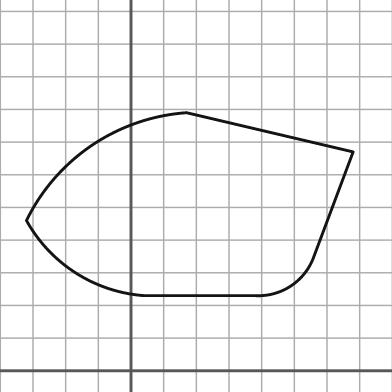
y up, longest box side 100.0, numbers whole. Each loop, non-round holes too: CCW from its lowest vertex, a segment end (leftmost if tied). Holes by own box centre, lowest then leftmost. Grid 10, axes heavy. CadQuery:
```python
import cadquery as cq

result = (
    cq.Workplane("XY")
    .moveTo(4.0, 23.0)
    .lineTo(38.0, 23.0)
    .threePointArc((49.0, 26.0), (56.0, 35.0))
    .lineTo(68.0, 67.0)
    .lineTo(17.0, 79.0)
    .threePointArc((-12.0, 69.0), (-32.0, 46.0))
    .threePointArc((-17.0, 30.0), (4.0, 23.0))
    .close()
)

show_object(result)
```